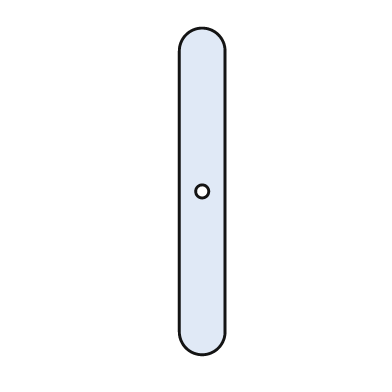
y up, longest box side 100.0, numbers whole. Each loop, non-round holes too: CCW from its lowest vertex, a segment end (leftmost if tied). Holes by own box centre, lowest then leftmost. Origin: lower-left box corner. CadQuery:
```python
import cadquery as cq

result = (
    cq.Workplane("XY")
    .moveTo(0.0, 7.0)
    .threePointArc((7.0, 0.0), (14.0, 7.0))
    .lineTo(14.0, 93.0)
    .threePointArc((7.0, 100.0), (0.0, 93.0))
    .close()
    .moveTo(7.0, 50.0)
    .circle(2.0)
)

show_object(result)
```